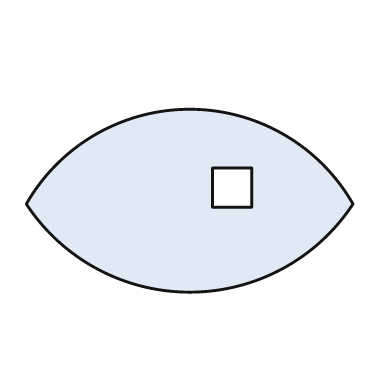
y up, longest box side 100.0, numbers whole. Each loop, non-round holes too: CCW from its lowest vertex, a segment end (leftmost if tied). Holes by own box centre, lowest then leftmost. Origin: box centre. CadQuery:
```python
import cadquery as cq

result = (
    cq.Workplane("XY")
    .moveTo(-50.0, -1.0)
    .threePointArc((0.0, -28.0), (50.0, -1.0))
    .threePointArc((0.0, 28.0), (-50.0, -1.0))
    .close()
    .moveTo(7.0, -2.0)
    .lineTo(19.0, -2.0)
    .lineTo(19.0, 10.0)
    .lineTo(7.0, 10.0)
    .close()
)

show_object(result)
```